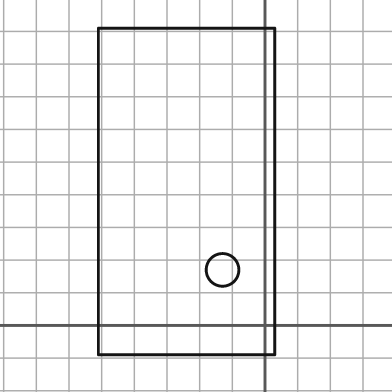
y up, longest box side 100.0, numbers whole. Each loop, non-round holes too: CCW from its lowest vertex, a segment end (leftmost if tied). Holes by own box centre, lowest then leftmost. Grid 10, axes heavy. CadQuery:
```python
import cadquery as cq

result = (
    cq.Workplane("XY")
    .moveTo(-51.0, -9.0)
    .lineTo(3.0, -9.0)
    .lineTo(3.0, 91.0)
    .lineTo(-51.0, 91.0)
    .close()
    .moveTo(-13.0, 17.0)
    .circle(5.0)
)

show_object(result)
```